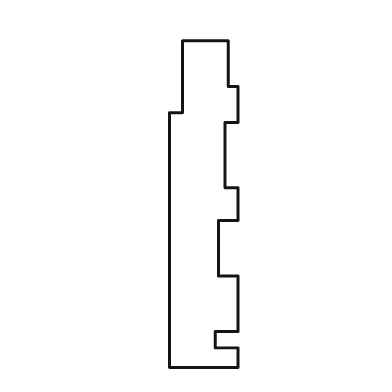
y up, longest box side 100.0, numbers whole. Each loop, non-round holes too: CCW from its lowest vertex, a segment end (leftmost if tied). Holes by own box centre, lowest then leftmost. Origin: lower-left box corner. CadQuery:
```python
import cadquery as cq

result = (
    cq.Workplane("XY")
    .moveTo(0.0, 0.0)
    .lineTo(21.0, 0.0)
    .lineTo(21.0, 6.0)
    .lineTo(14.0, 6.0)
    .lineTo(14.0, 11.0)
    .lineTo(21.0, 11.0)
    .lineTo(21.0, 28.0)
    .lineTo(15.0, 28.0)
    .lineTo(15.0, 45.0)
    .lineTo(21.0, 45.0)
    .lineTo(21.0, 55.0)
    .lineTo(17.0, 55.0)
    .lineTo(17.0, 75.0)
    .lineTo(21.0, 75.0)
    .lineTo(21.0, 86.0)
    .lineTo(18.0, 86.0)
    .lineTo(18.0, 100.0)
    .lineTo(4.0, 100.0)
    .lineTo(4.0, 78.0)
    .lineTo(0.0, 78.0)
    .close()
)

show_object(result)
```